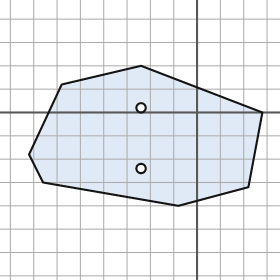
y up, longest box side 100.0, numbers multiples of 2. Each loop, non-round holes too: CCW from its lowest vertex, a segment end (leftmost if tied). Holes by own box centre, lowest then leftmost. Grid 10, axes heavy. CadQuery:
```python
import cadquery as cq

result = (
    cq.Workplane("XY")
    .moveTo(-8.0, -40.0)
    .lineTo(22.0, -32.0)
    .lineTo(28.0, 0.0)
    .lineTo(-24.0, 20.0)
    .lineTo(-58.0, 12.0)
    .lineTo(-72.0, -18.0)
    .lineTo(-66.0, -30.0)
    .close()
    .moveTo(-24.0, -24.0)
    .circle(2.0)
    .moveTo(-24.0, 2.0)
    .circle(2.0)
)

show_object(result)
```